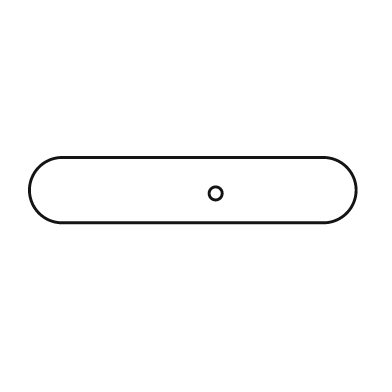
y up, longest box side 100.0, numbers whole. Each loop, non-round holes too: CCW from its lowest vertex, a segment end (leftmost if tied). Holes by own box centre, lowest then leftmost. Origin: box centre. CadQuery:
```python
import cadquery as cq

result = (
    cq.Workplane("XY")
    .moveTo(-40.0, -10.0)
    .lineTo(40.0, -10.0)
    .threePointArc((50.0, 0.0), (40.0, 10.0))
    .lineTo(-40.0, 10.0)
    .threePointArc((-50.0, 0.0), (-40.0, -10.0))
    .close()
    .moveTo(7.0, -1.0)
    .circle(2.0)
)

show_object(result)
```